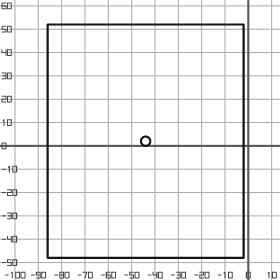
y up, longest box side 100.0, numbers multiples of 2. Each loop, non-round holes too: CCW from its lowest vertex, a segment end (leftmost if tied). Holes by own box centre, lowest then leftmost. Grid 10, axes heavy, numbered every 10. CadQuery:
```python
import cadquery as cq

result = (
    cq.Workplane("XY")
    .moveTo(-86.0, -48.0)
    .lineTo(-2.0, -48.0)
    .lineTo(-2.0, 52.0)
    .lineTo(-86.0, 52.0)
    .close()
    .moveTo(-44.0, 2.0)
    .circle(2.0)
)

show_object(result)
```